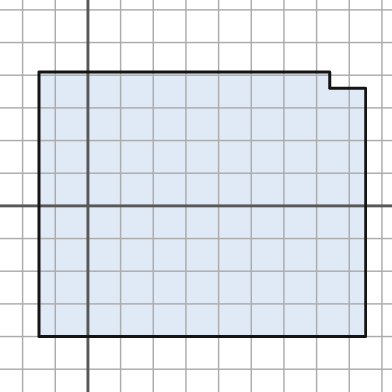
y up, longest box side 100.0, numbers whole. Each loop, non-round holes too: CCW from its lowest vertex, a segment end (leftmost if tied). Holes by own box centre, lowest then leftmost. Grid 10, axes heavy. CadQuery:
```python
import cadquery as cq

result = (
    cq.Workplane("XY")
    .moveTo(-15.0, -40.0)
    .lineTo(85.0, -40.0)
    .lineTo(85.0, 36.0)
    .lineTo(74.0, 36.0)
    .lineTo(74.0, 41.0)
    .lineTo(-15.0, 41.0)
    .close()
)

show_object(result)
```